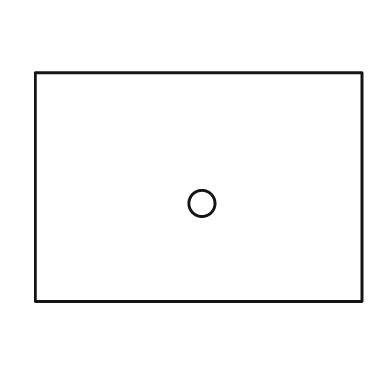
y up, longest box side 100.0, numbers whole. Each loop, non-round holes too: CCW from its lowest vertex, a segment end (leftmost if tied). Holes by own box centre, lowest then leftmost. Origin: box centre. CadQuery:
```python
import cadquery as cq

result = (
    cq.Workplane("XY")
    .moveTo(-50.0, -35.0)
    .lineTo(50.0, -35.0)
    .lineTo(50.0, 35.0)
    .lineTo(-50.0, 35.0)
    .close()
    .moveTo(1.0, -5.0)
    .circle(4.0)
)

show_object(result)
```